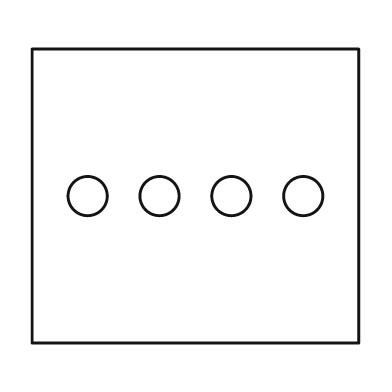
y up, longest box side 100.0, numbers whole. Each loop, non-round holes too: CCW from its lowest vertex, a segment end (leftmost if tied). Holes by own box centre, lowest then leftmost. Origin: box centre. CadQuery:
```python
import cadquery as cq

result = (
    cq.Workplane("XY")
    .moveTo(-50.0, -45.0)
    .lineTo(50.0, -45.0)
    .lineTo(50.0, 45.0)
    .lineTo(-50.0, 45.0)
    .close()
    .moveTo(-33.0, 0.0)
    .circle(6.0)
    .moveTo(-11.0, 0.0)
    .circle(6.0)
    .moveTo(11.0, 0.0)
    .circle(6.0)
    .moveTo(33.0, 0.0)
    .circle(6.0)
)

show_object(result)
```